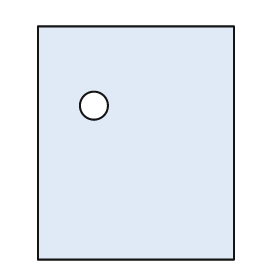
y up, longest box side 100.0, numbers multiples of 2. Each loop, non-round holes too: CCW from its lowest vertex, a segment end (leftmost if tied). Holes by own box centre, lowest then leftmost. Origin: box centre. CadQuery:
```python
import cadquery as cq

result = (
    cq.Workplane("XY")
    .moveTo(-42.0, -50.0)
    .lineTo(42.0, -50.0)
    .lineTo(42.0, 50.0)
    .lineTo(-42.0, 50.0)
    .close()
    .moveTo(-18.0, 16.0)
    .circle(6.0)
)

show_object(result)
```